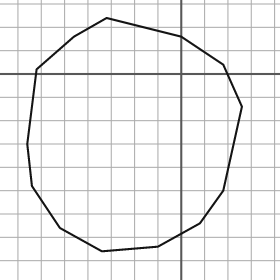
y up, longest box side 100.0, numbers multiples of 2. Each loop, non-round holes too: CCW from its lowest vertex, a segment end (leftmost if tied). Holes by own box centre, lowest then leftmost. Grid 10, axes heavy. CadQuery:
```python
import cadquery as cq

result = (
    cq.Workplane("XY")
    .moveTo(-34.0, -76.0)
    .lineTo(-10.0, -74.0)
    .lineTo(8.0, -64.0)
    .lineTo(18.0, -50.0)
    .lineTo(26.0, -14.0)
    .lineTo(18.0, 4.0)
    .lineTo(0.0, 16.0)
    .lineTo(-32.0, 24.0)
    .lineTo(-46.0, 16.0)
    .lineTo(-62.0, 2.0)
    .lineTo(-66.0, -30.0)
    .lineTo(-64.0, -48.0)
    .lineTo(-52.0, -66.0)
    .close()
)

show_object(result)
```